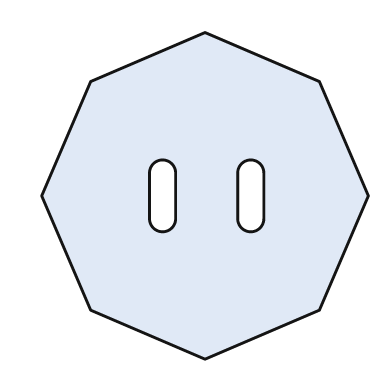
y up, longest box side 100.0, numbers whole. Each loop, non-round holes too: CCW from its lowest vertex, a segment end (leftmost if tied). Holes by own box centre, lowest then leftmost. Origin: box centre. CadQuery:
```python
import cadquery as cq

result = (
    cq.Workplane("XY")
    .moveTo(0.0, -50.0)
    .lineTo(35.0, -35.0)
    .lineTo(50.0, 0.0)
    .lineTo(35.0, 35.0)
    .lineTo(0.0, 50.0)
    .lineTo(-35.0, 35.0)
    .lineTo(-50.0, 0.0)
    .lineTo(-35.0, -35.0)
    .close()
    .moveTo(-17.0, -7.0)
    .threePointArc((-13.0, -11.0), (-9.0, -7.0))
    .lineTo(-9.0, 7.0)
    .threePointArc((-13.0, 11.0), (-17.0, 7.0))
    .close()
    .moveTo(10.0, -7.0)
    .threePointArc((14.0, -11.0), (18.0, -7.0))
    .lineTo(18.0, 7.0)
    .threePointArc((14.0, 11.0), (10.0, 7.0))
    .close()
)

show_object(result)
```